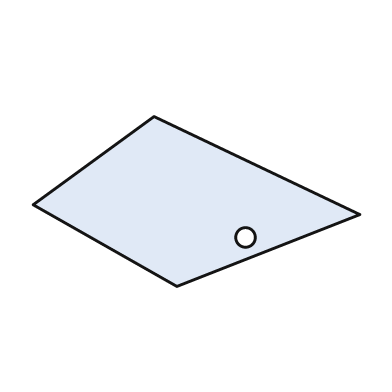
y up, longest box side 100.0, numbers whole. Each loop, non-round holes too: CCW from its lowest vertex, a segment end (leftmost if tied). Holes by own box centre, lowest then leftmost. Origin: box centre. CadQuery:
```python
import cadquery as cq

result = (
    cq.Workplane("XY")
    .moveTo(-6.0, -26.0)
    .lineTo(50.0, -4.0)
    .lineTo(-13.0, 26.0)
    .lineTo(-50.0, -1.0)
    .close()
    .moveTo(15.0, -11.0)
    .circle(3.0)
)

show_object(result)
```